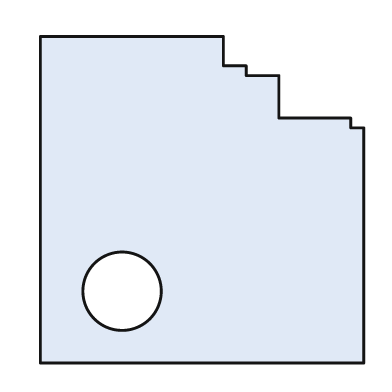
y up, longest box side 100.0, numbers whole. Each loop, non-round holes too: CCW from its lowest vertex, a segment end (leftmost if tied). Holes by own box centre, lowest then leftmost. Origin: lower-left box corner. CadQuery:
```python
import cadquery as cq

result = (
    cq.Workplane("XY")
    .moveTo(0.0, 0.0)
    .lineTo(99.0, 0.0)
    .lineTo(99.0, 72.0)
    .lineTo(95.0, 72.0)
    .lineTo(95.0, 75.0)
    .lineTo(73.0, 75.0)
    .lineTo(73.0, 88.0)
    .lineTo(63.0, 88.0)
    .lineTo(63.0, 91.0)
    .lineTo(56.0, 91.0)
    .lineTo(56.0, 100.0)
    .lineTo(0.0, 100.0)
    .close()
    .moveTo(25.0, 22.0)
    .circle(12.0)
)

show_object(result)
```